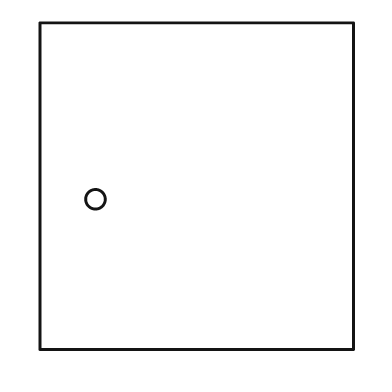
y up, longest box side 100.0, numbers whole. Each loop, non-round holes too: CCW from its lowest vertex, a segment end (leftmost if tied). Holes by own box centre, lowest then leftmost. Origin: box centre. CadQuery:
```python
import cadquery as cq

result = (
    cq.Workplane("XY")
    .moveTo(-48.0, -50.0)
    .lineTo(48.0, -50.0)
    .lineTo(48.0, 50.0)
    .lineTo(-48.0, 50.0)
    .close()
    .moveTo(-31.0, -4.0)
    .circle(3.0)
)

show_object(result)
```